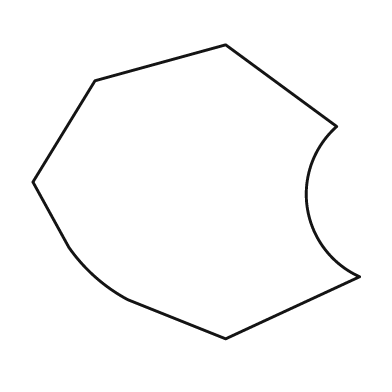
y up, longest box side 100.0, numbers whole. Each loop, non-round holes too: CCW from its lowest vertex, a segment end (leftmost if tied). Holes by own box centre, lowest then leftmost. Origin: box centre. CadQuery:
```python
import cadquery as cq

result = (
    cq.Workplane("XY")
    .moveTo(9.0, -45.0)
    .lineTo(50.0, -26.0)
    .threePointArc((34.0, -5.0), (43.0, 20.0))
    .lineTo(9.0, 45.0)
    .lineTo(-31.0, 34.0)
    .lineTo(-50.0, 3.0)
    .lineTo(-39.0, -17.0)
    .threePointArc((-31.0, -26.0), (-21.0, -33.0))
    .close()
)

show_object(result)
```